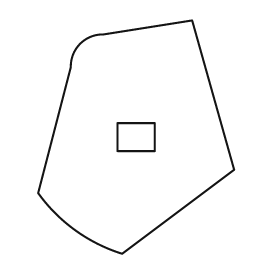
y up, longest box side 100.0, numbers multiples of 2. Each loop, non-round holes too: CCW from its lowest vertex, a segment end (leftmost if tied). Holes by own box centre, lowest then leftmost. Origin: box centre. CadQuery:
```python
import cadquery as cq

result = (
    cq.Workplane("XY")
    .moveTo(-6.0, -50.0)
    .lineTo(42.0, -14.0)
    .lineTo(24.0, 50.0)
    .lineTo(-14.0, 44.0)
    .threePointArc((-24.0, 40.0), (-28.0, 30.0))
    .lineTo(-42.0, -24.0)
    .threePointArc((-26.0, -40.0), (-6.0, -50.0))
    .close()
    .moveTo(-8.0, -6.0)
    .lineTo(8.0, -6.0)
    .lineTo(8.0, 6.0)
    .lineTo(-8.0, 6.0)
    .close()
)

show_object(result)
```